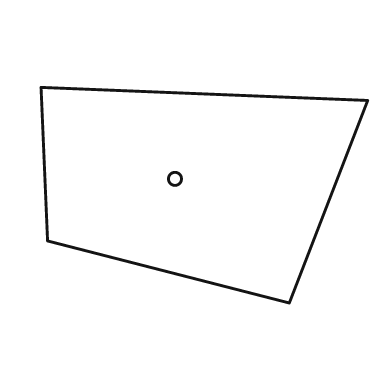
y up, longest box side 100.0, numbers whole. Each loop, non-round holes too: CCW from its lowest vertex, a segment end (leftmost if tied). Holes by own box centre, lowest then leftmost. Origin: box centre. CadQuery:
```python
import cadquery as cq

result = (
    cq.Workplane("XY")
    .moveTo(26.0, -33.0)
    .lineTo(50.0, 29.0)
    .lineTo(-50.0, 33.0)
    .lineTo(-48.0, -14.0)
    .close()
    .moveTo(-9.0, 5.0)
    .circle(2.0)
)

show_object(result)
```